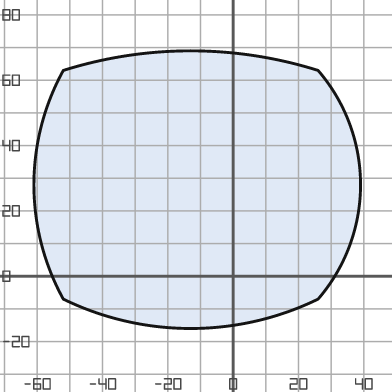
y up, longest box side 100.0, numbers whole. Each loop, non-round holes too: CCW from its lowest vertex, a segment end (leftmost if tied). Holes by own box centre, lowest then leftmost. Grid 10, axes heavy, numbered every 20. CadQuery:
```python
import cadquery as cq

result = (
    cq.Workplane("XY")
    .moveTo(-52.0, -7.0)
    .threePointArc((-13.0, -16.0), (26.0, -7.0))
    .threePointArc((39.0, 28.0), (26.0, 63.0))
    .threePointArc((-13.0, 69.0), (-52.0, 63.0))
    .threePointArc((-61.0, 28.0), (-52.0, -7.0))
    .close()
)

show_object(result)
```